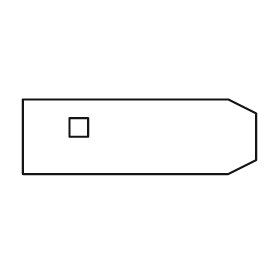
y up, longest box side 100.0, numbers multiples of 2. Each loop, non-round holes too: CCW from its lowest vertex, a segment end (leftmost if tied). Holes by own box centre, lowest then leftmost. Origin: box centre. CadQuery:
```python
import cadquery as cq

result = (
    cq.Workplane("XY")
    .moveTo(-50.0, -16.0)
    .lineTo(38.0, -16.0)
    .lineTo(50.0, -10.0)
    .lineTo(50.0, 10.0)
    .lineTo(38.0, 16.0)
    .lineTo(-50.0, 16.0)
    .close()
    .moveTo(-30.0, 0.0)
    .lineTo(-22.0, 0.0)
    .lineTo(-22.0, 8.0)
    .lineTo(-30.0, 8.0)
    .close()
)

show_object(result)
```